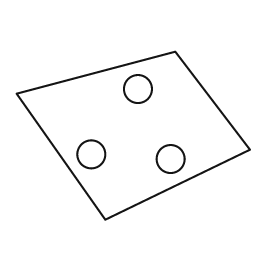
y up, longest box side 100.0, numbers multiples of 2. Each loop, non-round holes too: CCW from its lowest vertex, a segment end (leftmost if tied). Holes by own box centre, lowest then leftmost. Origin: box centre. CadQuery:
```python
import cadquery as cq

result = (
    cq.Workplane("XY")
    .moveTo(-12.0, -36.0)
    .lineTo(50.0, -6.0)
    .lineTo(18.0, 36.0)
    .lineTo(-50.0, 18.0)
    .close()
    .moveTo(16.0, -10.0)
    .circle(6.0)
    .moveTo(-18.0, -8.0)
    .circle(6.0)
    .moveTo(2.0, 20.0)
    .circle(6.0)
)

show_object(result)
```